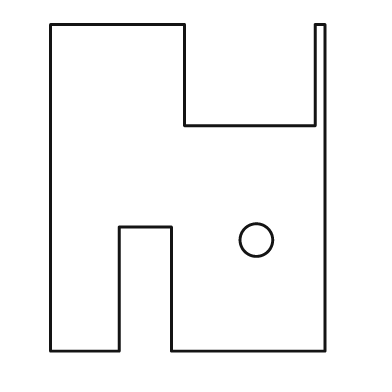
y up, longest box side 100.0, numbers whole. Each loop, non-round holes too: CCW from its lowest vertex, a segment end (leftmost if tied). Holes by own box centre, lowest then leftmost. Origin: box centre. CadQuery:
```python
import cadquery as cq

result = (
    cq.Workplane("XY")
    .moveTo(-42.0, -50.0)
    .lineTo(-21.0, -50.0)
    .lineTo(-21.0, -12.0)
    .lineTo(-5.0, -12.0)
    .lineTo(-5.0, -50.0)
    .lineTo(42.0, -50.0)
    .lineTo(42.0, 50.0)
    .lineTo(39.0, 50.0)
    .lineTo(39.0, 19.0)
    .lineTo(-1.0, 19.0)
    .lineTo(-1.0, 50.0)
    .lineTo(-42.0, 50.0)
    .close()
    .moveTo(21.0, -16.0)
    .circle(5.0)
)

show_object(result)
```